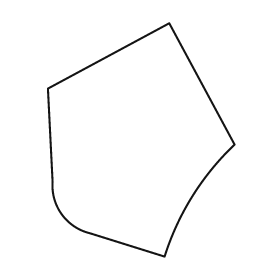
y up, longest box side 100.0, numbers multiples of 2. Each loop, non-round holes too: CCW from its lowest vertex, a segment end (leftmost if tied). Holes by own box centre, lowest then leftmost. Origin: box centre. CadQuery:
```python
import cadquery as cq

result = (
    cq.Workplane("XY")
    .moveTo(10.0, -50.0)
    .threePointArc((22.0, -24.0), (40.0, -2.0))
    .lineTo(12.0, 50.0)
    .lineTo(-40.0, 22.0)
    .lineTo(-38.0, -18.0)
    .threePointArc((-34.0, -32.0), (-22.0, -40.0))
    .close()
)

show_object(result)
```